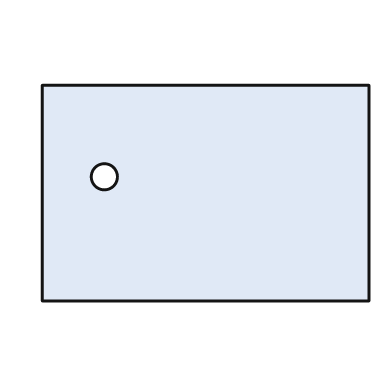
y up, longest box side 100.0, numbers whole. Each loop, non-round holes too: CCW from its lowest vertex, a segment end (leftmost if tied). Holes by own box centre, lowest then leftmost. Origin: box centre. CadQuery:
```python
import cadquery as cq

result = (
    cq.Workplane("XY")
    .moveTo(-50.0, -33.0)
    .lineTo(50.0, -33.0)
    .lineTo(50.0, 33.0)
    .lineTo(-50.0, 33.0)
    .close()
    .moveTo(-31.0, 5.0)
    .circle(4.0)
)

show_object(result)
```